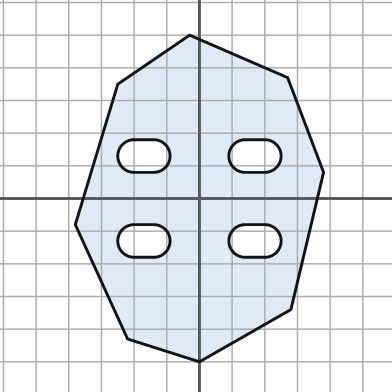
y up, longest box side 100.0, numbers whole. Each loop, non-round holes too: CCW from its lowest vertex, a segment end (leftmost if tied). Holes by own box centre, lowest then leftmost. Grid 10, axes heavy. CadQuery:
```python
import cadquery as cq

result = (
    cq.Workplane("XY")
    .moveTo(0.0, -50.0)
    .lineTo(28.0, -34.0)
    .lineTo(38.0, 8.0)
    .lineTo(27.0, 37.0)
    .lineTo(-3.0, 50.0)
    .lineTo(-25.0, 35.0)
    .lineTo(-38.0, -8.0)
    .lineTo(-22.0, -43.0)
    .close()
    .moveTo(-20.0, -18.0)
    .lineTo(-14.0, -18.0)
    .threePointArc((-9.0, -13.0), (-14.0, -8.0))
    .lineTo(-20.0, -8.0)
    .threePointArc((-25.0, -13.0), (-20.0, -18.0))
    .close()
    .moveTo(14.0, -18.0)
    .lineTo(20.0, -18.0)
    .threePointArc((25.0, -13.0), (20.0, -8.0))
    .lineTo(14.0, -8.0)
    .threePointArc((9.0, -13.0), (14.0, -18.0))
    .close()
    .moveTo(-20.0, 8.0)
    .lineTo(-14.0, 8.0)
    .threePointArc((-9.0, 13.0), (-14.0, 18.0))
    .lineTo(-20.0, 18.0)
    .threePointArc((-25.0, 13.0), (-20.0, 8.0))
    .close()
    .moveTo(14.0, 8.0)
    .lineTo(20.0, 8.0)
    .threePointArc((25.0, 13.0), (20.0, 18.0))
    .lineTo(14.0, 18.0)
    .threePointArc((9.0, 13.0), (14.0, 8.0))
    .close()
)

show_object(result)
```